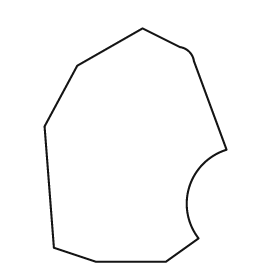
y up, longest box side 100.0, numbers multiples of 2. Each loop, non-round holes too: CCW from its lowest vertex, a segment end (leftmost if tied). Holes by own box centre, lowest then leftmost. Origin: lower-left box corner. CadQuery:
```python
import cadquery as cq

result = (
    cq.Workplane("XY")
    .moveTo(22.0, 0.0)
    .lineTo(52.0, 0.0)
    .lineTo(66.0, 10.0)
    .threePointArc((62.0, 32.0), (78.0, 48.0))
    .lineTo(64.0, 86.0)
    .threePointArc((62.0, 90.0), (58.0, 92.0))
    .lineTo(42.0, 100.0)
    .lineTo(14.0, 84.0)
    .lineTo(0.0, 58.0)
    .lineTo(4.0, 6.0)
    .close()
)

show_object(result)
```